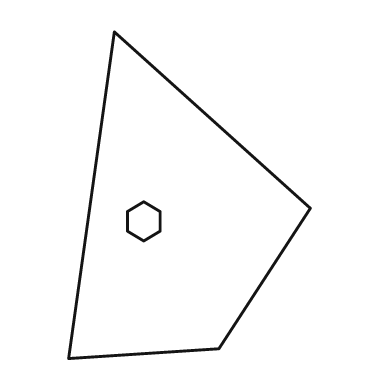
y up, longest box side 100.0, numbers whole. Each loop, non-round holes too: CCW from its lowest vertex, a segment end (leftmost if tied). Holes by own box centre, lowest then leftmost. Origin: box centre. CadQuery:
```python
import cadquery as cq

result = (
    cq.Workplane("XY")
    .moveTo(-37.0, -50.0)
    .lineTo(9.0, -47.0)
    .lineTo(37.0, -4.0)
    .lineTo(-23.0, 50.0)
    .close()
    .moveTo(-14.0, -14.0)
    .lineTo(-9.0, -11.0)
    .lineTo(-9.0, -5.0)
    .lineTo(-14.0, -2.0)
    .lineTo(-19.0, -5.0)
    .lineTo(-19.0, -11.0)
    .close()
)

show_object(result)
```